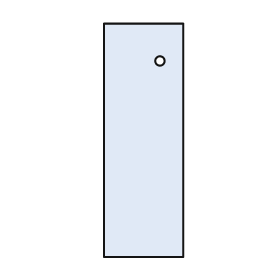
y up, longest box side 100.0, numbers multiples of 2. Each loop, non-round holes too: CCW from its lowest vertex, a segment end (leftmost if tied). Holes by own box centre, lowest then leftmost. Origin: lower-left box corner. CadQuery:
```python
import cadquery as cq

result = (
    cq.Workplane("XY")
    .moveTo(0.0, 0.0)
    .lineTo(34.0, 0.0)
    .lineTo(34.0, 100.0)
    .lineTo(0.0, 100.0)
    .close()
    .moveTo(24.0, 84.0)
    .circle(2.0)
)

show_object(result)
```